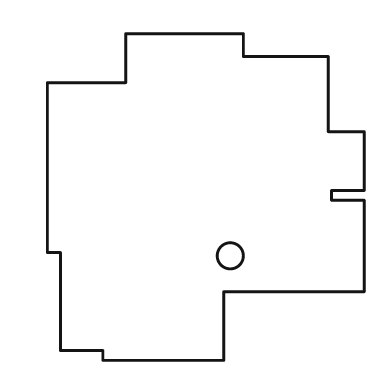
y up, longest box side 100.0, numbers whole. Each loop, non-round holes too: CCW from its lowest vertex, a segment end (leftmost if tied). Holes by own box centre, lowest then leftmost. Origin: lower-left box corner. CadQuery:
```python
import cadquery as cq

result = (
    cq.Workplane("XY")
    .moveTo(17.0, 0.0)
    .lineTo(54.0, 0.0)
    .lineTo(54.0, 21.0)
    .lineTo(97.0, 21.0)
    .lineTo(97.0, 49.0)
    .lineTo(87.0, 49.0)
    .lineTo(87.0, 52.0)
    .lineTo(97.0, 52.0)
    .lineTo(97.0, 70.0)
    .lineTo(86.0, 70.0)
    .lineTo(86.0, 93.0)
    .lineTo(60.0, 93.0)
    .lineTo(60.0, 100.0)
    .lineTo(24.0, 100.0)
    .lineTo(24.0, 85.0)
    .lineTo(0.0, 85.0)
    .lineTo(0.0, 33.0)
    .lineTo(4.0, 33.0)
    .lineTo(4.0, 3.0)
    .lineTo(17.0, 3.0)
    .close()
    .moveTo(56.0, 32.0)
    .circle(4.0)
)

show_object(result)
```